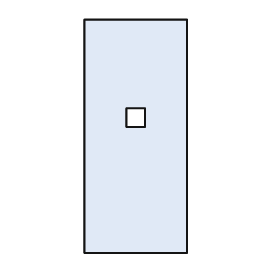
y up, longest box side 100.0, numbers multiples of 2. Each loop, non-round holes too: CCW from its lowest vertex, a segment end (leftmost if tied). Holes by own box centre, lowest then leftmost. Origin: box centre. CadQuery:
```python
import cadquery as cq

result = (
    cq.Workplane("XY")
    .moveTo(-22.0, -50.0)
    .lineTo(22.0, -50.0)
    .lineTo(22.0, 50.0)
    .lineTo(-22.0, 50.0)
    .close()
    .moveTo(-4.0, 4.0)
    .lineTo(4.0, 4.0)
    .lineTo(4.0, 12.0)
    .lineTo(-4.0, 12.0)
    .close()
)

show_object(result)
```